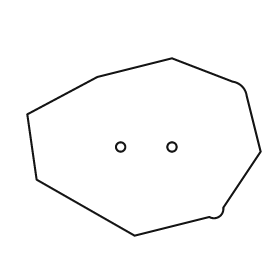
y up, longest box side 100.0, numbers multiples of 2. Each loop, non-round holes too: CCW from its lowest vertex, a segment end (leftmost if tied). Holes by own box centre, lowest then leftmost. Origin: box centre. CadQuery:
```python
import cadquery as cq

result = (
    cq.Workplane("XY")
    .moveTo(-4.0, -38.0)
    .lineTo(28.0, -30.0)
    .threePointArc((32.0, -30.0), (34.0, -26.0))
    .lineTo(50.0, -2.0)
    .lineTo(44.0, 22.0)
    .threePointArc((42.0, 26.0), (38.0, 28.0))
    .lineTo(12.0, 38.0)
    .lineTo(-20.0, 30.0)
    .lineTo(-50.0, 14.0)
    .lineTo(-46.0, -14.0)
    .close()
    .moveTo(-10.0, 0.0)
    .circle(2.0)
    .moveTo(12.0, 0.0)
    .circle(2.0)
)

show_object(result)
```